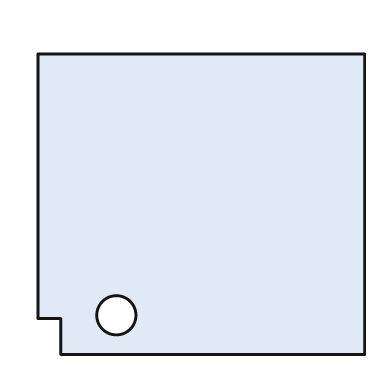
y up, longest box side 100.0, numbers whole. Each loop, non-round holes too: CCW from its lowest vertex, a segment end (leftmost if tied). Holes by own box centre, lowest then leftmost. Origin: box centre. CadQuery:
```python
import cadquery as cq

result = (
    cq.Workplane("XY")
    .moveTo(-43.0, -46.0)
    .lineTo(50.0, -46.0)
    .lineTo(50.0, 46.0)
    .lineTo(-50.0, 46.0)
    .lineTo(-50.0, -35.0)
    .lineTo(-43.0, -35.0)
    .close()
    .moveTo(-26.0, -34.0)
    .circle(6.0)
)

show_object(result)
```